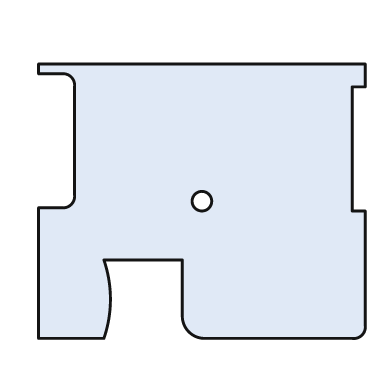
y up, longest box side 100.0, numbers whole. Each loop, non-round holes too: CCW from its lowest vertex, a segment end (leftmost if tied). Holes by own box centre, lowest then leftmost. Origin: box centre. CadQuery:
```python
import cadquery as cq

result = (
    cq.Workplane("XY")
    .moveTo(-50.0, -42.0)
    .lineTo(-30.0, -42.0)
    .threePointArc((-28.0, -30.0), (-30.0, -18.0))
    .lineTo(-6.0, -18.0)
    .lineTo(-6.0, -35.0)
    .threePointArc((-4.0, -40.0), (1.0, -42.0))
    .lineTo(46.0, -42.0)
    .threePointArc((49.0, -41.0), (50.0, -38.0))
    .lineTo(50.0, -3.0)
    .lineTo(46.0, -3.0)
    .lineTo(46.0, 35.0)
    .lineTo(50.0, 35.0)
    .lineTo(50.0, 42.0)
    .lineTo(-50.0, 42.0)
    .lineTo(-50.0, 39.0)
    .lineTo(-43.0, 39.0)
    .threePointArc((-40.0, 38.0), (-39.0, 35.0))
    .lineTo(-39.0, 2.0)
    .threePointArc((-40.0, -1.0), (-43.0, -2.0))
    .lineTo(-50.0, -2.0)
    .close()
    .moveTo(0.0, 0.0)
    .circle(3.0)
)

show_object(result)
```